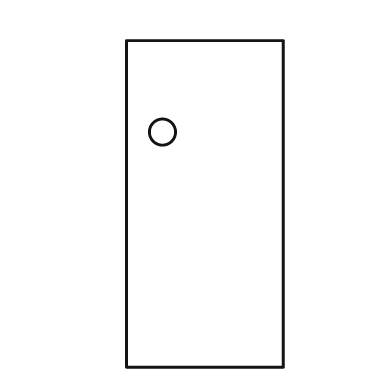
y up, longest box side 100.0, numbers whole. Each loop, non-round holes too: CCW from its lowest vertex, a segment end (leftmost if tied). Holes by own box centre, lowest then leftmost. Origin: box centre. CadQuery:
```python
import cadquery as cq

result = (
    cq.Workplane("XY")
    .moveTo(-24.0, -50.0)
    .lineTo(24.0, -50.0)
    .lineTo(24.0, 50.0)
    .lineTo(-24.0, 50.0)
    .close()
    .moveTo(-13.0, 22.0)
    .circle(4.0)
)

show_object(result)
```